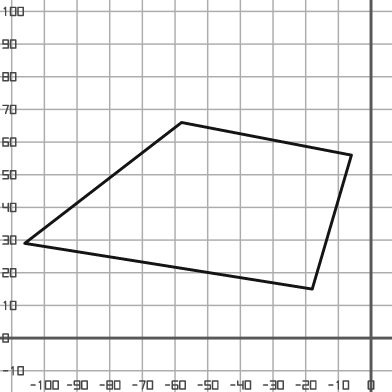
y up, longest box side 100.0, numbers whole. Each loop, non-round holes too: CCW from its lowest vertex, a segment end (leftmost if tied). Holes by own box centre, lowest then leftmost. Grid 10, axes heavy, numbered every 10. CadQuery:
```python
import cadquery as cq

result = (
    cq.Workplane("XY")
    .moveTo(-18.0, 15.0)
    .lineTo(-6.0, 56.0)
    .lineTo(-58.0, 66.0)
    .lineTo(-106.0, 29.0)
    .close()
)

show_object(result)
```